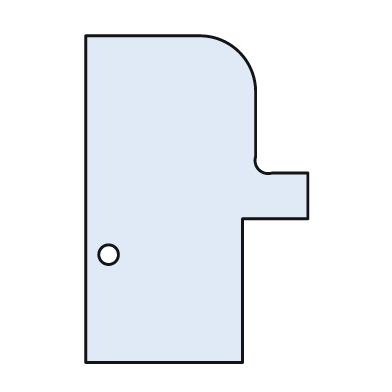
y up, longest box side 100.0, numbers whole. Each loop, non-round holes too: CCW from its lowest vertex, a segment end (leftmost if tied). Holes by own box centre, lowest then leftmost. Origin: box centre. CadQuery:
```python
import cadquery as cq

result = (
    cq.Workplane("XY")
    .moveTo(-34.0, -50.0)
    .lineTo(14.0, -50.0)
    .lineTo(14.0, -6.0)
    .lineTo(34.0, -6.0)
    .lineTo(34.0, 8.0)
    .lineTo(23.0, 8.0)
    .threePointArc((19.0, 9.0), (18.0, 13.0))
    .lineTo(18.0, 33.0)
    .threePointArc((13.0, 45.0), (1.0, 50.0))
    .lineTo(-34.0, 50.0)
    .close()
    .moveTo(-27.0, -17.0)
    .circle(3.0)
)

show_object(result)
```